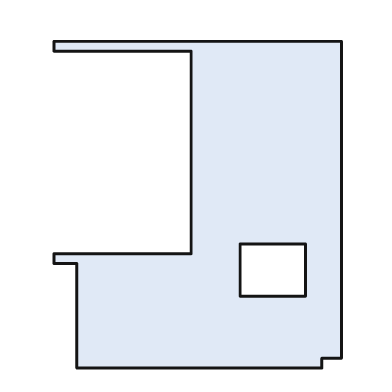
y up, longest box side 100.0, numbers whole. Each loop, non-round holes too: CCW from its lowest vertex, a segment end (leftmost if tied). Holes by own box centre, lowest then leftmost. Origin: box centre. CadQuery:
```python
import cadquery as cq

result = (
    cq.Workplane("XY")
    .moveTo(-37.0, -50.0)
    .lineTo(38.0, -50.0)
    .lineTo(38.0, -47.0)
    .lineTo(44.0, -47.0)
    .lineTo(44.0, 50.0)
    .lineTo(-44.0, 50.0)
    .lineTo(-44.0, 47.0)
    .lineTo(-2.0, 47.0)
    .lineTo(-2.0, -15.0)
    .lineTo(-44.0, -15.0)
    .lineTo(-44.0, -18.0)
    .lineTo(-37.0, -18.0)
    .close()
    .moveTo(13.0, -28.0)
    .lineTo(33.0, -28.0)
    .lineTo(33.0, -12.0)
    .lineTo(13.0, -12.0)
    .close()
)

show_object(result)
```